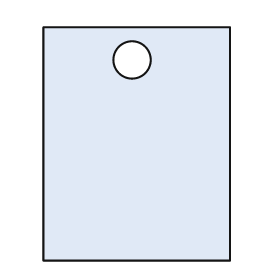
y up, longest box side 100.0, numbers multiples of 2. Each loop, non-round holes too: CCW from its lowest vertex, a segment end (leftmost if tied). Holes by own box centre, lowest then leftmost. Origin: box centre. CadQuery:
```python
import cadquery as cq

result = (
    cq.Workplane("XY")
    .moveTo(-40.0, -50.0)
    .lineTo(40.0, -50.0)
    .lineTo(40.0, 50.0)
    .lineTo(-40.0, 50.0)
    .close()
    .moveTo(-2.0, 36.0)
    .circle(8.0)
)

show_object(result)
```